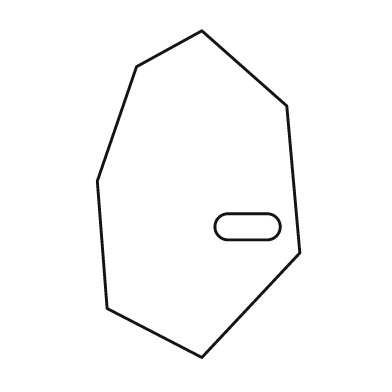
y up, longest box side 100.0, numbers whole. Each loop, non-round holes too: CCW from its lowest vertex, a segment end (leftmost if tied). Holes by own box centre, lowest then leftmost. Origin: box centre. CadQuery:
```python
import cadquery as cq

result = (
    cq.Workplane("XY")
    .moveTo(1.0, -50.0)
    .lineTo(31.0, -18.0)
    .lineTo(27.0, 27.0)
    .lineTo(1.0, 50.0)
    .lineTo(-19.0, 39.0)
    .lineTo(-31.0, 4.0)
    .lineTo(-28.0, -35.0)
    .close()
    .moveTo(9.0, -14.0)
    .lineTo(21.0, -14.0)
    .threePointArc((25.0, -10.0), (21.0, -6.0))
    .lineTo(9.0, -6.0)
    .threePointArc((5.0, -10.0), (9.0, -14.0))
    .close()
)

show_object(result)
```